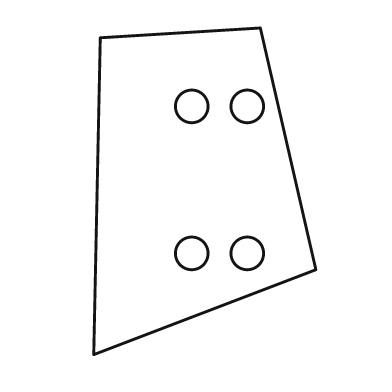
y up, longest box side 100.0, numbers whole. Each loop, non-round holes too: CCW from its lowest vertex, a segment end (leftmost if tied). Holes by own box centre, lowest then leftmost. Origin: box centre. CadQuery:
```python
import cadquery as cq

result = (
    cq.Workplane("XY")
    .moveTo(-34.0, -50.0)
    .lineTo(34.0, -24.0)
    .lineTo(17.0, 50.0)
    .lineTo(-32.0, 47.0)
    .close()
    .moveTo(-4.0, -19.0)
    .circle(5.0)
    .moveTo(13.0, -19.0)
    .circle(5.0)
    .moveTo(-4.0, 26.0)
    .circle(5.0)
    .moveTo(13.0, 26.0)
    .circle(5.0)
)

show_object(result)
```